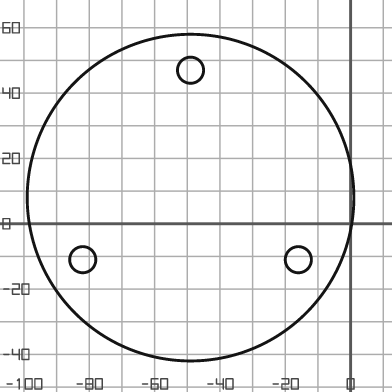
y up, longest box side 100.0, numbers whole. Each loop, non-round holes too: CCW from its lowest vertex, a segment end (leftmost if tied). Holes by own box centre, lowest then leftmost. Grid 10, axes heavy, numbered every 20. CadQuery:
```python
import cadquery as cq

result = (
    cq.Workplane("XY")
    .moveTo(-49.0, 8.0)
    .circle(50.0)
    .moveTo(-82.0, -11.0)
    .circle(4.0)
    .moveTo(-16.0, -11.0)
    .circle(4.0)
    .moveTo(-49.0, 47.0)
    .circle(4.0)
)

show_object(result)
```